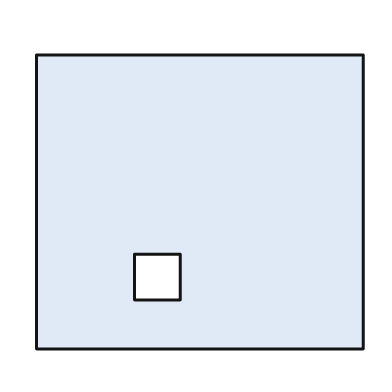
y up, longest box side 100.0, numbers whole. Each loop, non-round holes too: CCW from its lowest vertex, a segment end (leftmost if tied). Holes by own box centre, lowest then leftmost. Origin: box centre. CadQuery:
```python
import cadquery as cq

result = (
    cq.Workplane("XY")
    .moveTo(-50.0, -45.0)
    .lineTo(50.0, -45.0)
    .lineTo(50.0, 45.0)
    .lineTo(-50.0, 45.0)
    .close()
    .moveTo(-20.0, -30.0)
    .lineTo(-6.0, -30.0)
    .lineTo(-6.0, -16.0)
    .lineTo(-20.0, -16.0)
    .close()
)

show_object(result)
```